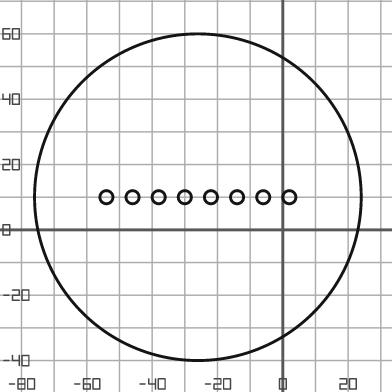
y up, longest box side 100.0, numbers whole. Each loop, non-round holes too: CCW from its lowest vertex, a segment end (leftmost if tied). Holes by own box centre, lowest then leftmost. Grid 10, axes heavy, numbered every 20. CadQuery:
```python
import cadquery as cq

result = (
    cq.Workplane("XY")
    .moveTo(-26.0, 10.0)
    .circle(50.0)
    .moveTo(-54.0, 10.0)
    .circle(2.0)
    .moveTo(-46.0, 10.0)
    .circle(2.0)
    .moveTo(-38.0, 10.0)
    .circle(2.0)
    .moveTo(-30.0, 10.0)
    .circle(2.0)
    .moveTo(-22.0, 10.0)
    .circle(2.0)
    .moveTo(-14.0, 10.0)
    .circle(2.0)
    .moveTo(-6.0, 10.0)
    .circle(2.0)
    .moveTo(2.0, 10.0)
    .circle(2.0)
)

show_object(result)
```